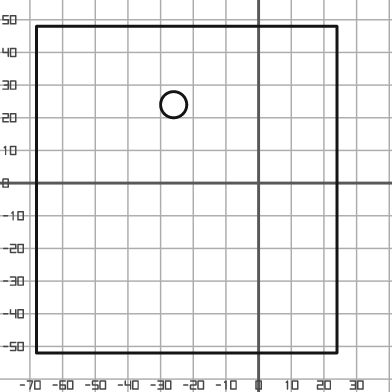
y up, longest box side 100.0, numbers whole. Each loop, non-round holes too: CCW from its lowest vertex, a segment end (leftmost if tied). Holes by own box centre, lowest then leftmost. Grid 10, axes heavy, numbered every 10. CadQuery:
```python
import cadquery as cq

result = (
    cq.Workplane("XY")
    .moveTo(-68.0, -52.0)
    .lineTo(24.0, -52.0)
    .lineTo(24.0, 48.0)
    .lineTo(-68.0, 48.0)
    .close()
    .moveTo(-26.0, 24.0)
    .circle(4.0)
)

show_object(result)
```